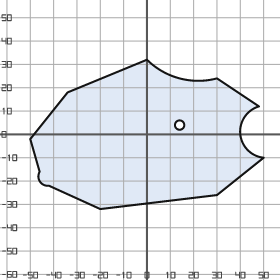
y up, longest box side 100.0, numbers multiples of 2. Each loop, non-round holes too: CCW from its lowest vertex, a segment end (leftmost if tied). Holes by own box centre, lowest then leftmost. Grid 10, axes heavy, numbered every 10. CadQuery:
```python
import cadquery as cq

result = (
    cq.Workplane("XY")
    .moveTo(-20.0, -32.0)
    .lineTo(30.0, -26.0)
    .lineTo(50.0, -10.0)
    .threePointArc((40.0, 0.0), (48.0, 12.0))
    .lineTo(30.0, 24.0)
    .threePointArc((14.0, 24.0), (0.0, 32.0))
    .lineTo(-34.0, 18.0)
    .lineTo(-50.0, -2.0)
    .lineTo(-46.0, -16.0)
    .threePointArc((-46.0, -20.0), (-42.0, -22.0))
    .close()
    .moveTo(14.0, 4.0)
    .circle(2.0)
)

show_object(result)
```